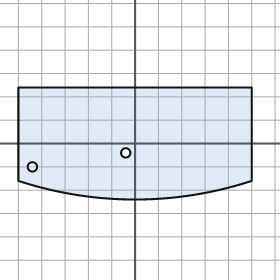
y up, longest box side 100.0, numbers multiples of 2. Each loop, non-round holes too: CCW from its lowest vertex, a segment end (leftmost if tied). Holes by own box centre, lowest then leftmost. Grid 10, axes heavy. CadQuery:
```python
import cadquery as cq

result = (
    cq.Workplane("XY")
    .moveTo(-50.0, -16.0)
    .threePointArc((0.0, -24.0), (50.0, -16.0))
    .lineTo(50.0, 24.0)
    .lineTo(-50.0, 24.0)
    .close()
    .moveTo(-44.0, -10.0)
    .circle(2.0)
    .moveTo(-4.0, -4.0)
    .circle(2.0)
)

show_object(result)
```